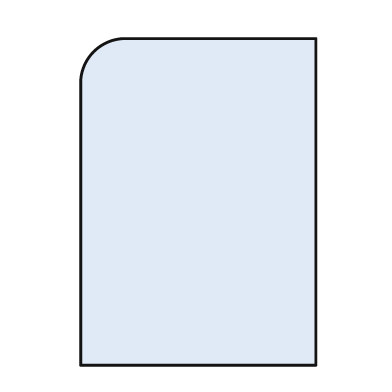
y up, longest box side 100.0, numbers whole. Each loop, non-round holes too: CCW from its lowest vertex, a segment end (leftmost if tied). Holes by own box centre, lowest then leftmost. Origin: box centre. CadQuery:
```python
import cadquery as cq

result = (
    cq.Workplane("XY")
    .moveTo(-36.0, -50.0)
    .lineTo(36.0, -50.0)
    .lineTo(36.0, 50.0)
    .lineTo(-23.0, 50.0)
    .threePointArc((-32.0, 46.0), (-36.0, 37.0))
    .close()
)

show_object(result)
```